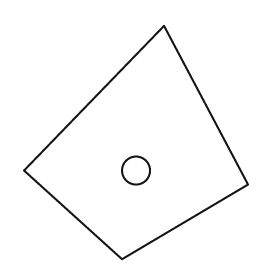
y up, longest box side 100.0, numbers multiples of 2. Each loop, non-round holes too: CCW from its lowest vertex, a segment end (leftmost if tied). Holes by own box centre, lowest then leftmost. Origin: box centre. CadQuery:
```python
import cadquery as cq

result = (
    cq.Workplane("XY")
    .moveTo(-6.0, -50.0)
    .lineTo(48.0, -18.0)
    .lineTo(12.0, 50.0)
    .lineTo(-48.0, -12.0)
    .close()
    .moveTo(0.0, -12.0)
    .circle(6.0)
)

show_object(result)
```